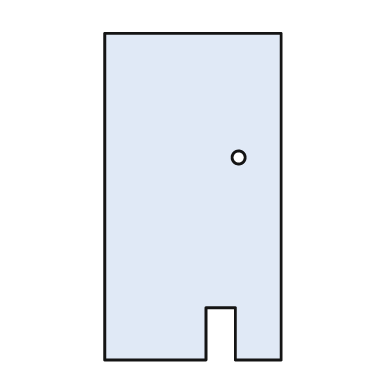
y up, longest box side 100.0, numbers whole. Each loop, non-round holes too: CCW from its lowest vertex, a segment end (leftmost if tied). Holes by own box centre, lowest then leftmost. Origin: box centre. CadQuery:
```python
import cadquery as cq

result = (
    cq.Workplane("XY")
    .moveTo(-27.0, -50.0)
    .lineTo(4.0, -50.0)
    .lineTo(4.0, -34.0)
    .lineTo(13.0, -34.0)
    .lineTo(13.0, -50.0)
    .lineTo(27.0, -50.0)
    .lineTo(27.0, 50.0)
    .lineTo(-27.0, 50.0)
    .close()
    .moveTo(14.0, 12.0)
    .circle(2.0)
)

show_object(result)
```